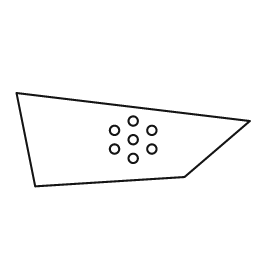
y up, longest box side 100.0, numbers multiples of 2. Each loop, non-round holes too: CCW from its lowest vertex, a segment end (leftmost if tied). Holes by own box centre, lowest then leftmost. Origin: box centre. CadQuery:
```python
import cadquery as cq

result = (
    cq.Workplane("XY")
    .moveTo(-42.0, -20.0)
    .lineTo(22.0, -16.0)
    .lineTo(50.0, 8.0)
    .lineTo(-50.0, 20.0)
    .close()
    .moveTo(0.0, -8.0)
    .circle(2.0)
    .moveTo(-8.0, -4.0)
    .circle(2.0)
    .moveTo(8.0, -4.0)
    .circle(2.0)
    .moveTo(0.0, 0.0)
    .circle(2.0)
    .moveTo(-8.0, 4.0)
    .circle(2.0)
    .moveTo(8.0, 4.0)
    .circle(2.0)
    .moveTo(0.0, 8.0)
    .circle(2.0)
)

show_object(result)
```